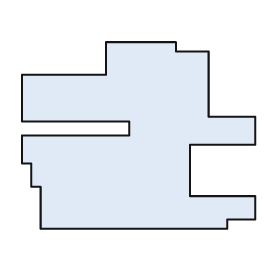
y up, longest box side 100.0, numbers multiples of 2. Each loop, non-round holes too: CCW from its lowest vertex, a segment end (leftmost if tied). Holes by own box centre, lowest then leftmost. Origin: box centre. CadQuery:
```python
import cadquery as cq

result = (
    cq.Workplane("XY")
    .moveTo(-42.0, -40.0)
    .lineTo(38.0, -40.0)
    .lineTo(38.0, -36.0)
    .lineTo(50.0, -36.0)
    .lineTo(50.0, -26.0)
    .lineTo(22.0, -26.0)
    .lineTo(22.0, -4.0)
    .lineTo(50.0, -4.0)
    .lineTo(50.0, 8.0)
    .lineTo(30.0, 8.0)
    .lineTo(30.0, 36.0)
    .lineTo(16.0, 36.0)
    .lineTo(16.0, 40.0)
    .lineTo(-14.0, 40.0)
    .lineTo(-14.0, 26.0)
    .lineTo(-50.0, 26.0)
    .lineTo(-50.0, 6.0)
    .lineTo(-4.0, 6.0)
    .lineTo(-4.0, 0.0)
    .lineTo(-50.0, 0.0)
    .lineTo(-50.0, -12.0)
    .lineTo(-46.0, -12.0)
    .lineTo(-46.0, -22.0)
    .lineTo(-42.0, -22.0)
    .close()
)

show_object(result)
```